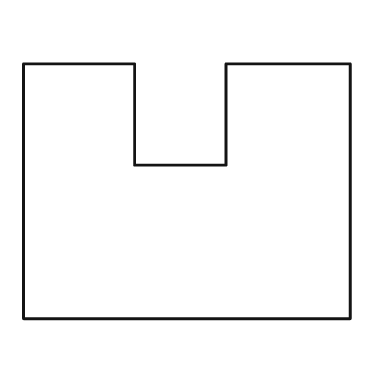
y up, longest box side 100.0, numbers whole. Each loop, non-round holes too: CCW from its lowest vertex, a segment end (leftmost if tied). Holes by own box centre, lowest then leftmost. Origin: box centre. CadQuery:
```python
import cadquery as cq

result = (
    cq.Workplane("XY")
    .moveTo(-50.0, -39.0)
    .lineTo(50.0, -39.0)
    .lineTo(50.0, 39.0)
    .lineTo(12.0, 39.0)
    .lineTo(12.0, 8.0)
    .lineTo(-16.0, 8.0)
    .lineTo(-16.0, 39.0)
    .lineTo(-50.0, 39.0)
    .close()
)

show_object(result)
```